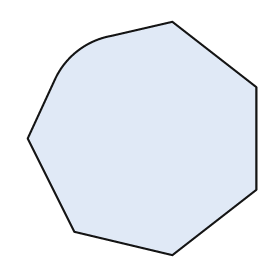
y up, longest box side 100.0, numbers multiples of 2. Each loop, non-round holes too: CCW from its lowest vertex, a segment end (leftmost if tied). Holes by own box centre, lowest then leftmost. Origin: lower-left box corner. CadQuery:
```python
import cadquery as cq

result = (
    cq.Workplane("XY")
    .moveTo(62.0, 0.0)
    .lineTo(98.0, 28.0)
    .lineTo(98.0, 72.0)
    .lineTo(62.0, 100.0)
    .lineTo(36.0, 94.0)
    .threePointArc((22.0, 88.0), (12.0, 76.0))
    .lineTo(0.0, 50.0)
    .lineTo(20.0, 10.0)
    .close()
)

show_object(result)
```